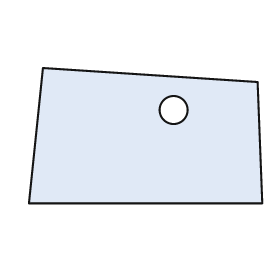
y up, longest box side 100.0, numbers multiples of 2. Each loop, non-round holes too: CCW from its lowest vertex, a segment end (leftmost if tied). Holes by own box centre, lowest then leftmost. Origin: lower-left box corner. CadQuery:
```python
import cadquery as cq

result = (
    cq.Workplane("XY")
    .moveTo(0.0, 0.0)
    .lineTo(100.0, 0.0)
    .lineTo(98.0, 52.0)
    .lineTo(6.0, 58.0)
    .close()
    .moveTo(62.0, 40.0)
    .circle(6.0)
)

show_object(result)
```